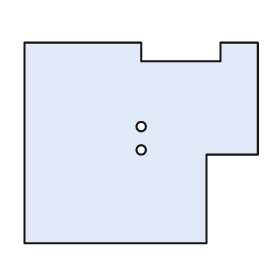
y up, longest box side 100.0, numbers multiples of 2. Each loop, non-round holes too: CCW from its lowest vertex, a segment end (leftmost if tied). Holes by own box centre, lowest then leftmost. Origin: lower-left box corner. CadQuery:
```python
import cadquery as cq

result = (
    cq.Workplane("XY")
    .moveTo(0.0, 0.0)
    .lineTo(78.0, 0.0)
    .lineTo(78.0, 38.0)
    .lineTo(100.0, 38.0)
    .lineTo(100.0, 86.0)
    .lineTo(84.0, 86.0)
    .lineTo(84.0, 78.0)
    .lineTo(50.0, 78.0)
    .lineTo(50.0, 86.0)
    .lineTo(0.0, 86.0)
    .close()
    .moveTo(50.0, 40.0)
    .circle(2.0)
    .moveTo(50.0, 50.0)
    .circle(2.0)
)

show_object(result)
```